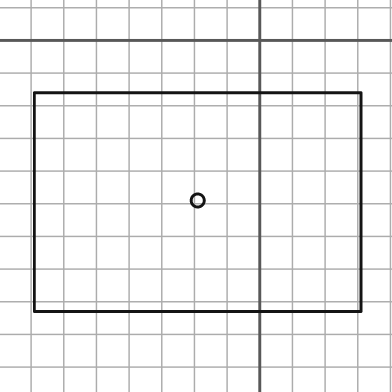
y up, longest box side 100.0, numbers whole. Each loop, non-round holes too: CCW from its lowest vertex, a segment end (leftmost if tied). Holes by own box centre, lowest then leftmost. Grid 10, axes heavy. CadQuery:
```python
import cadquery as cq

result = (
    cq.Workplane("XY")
    .moveTo(-69.0, -83.0)
    .lineTo(31.0, -83.0)
    .lineTo(31.0, -16.0)
    .lineTo(-69.0, -16.0)
    .close()
    .moveTo(-19.0, -49.0)
    .circle(2.0)
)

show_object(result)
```